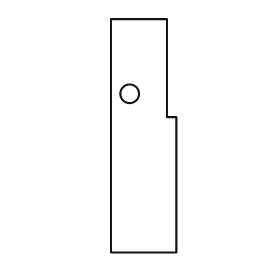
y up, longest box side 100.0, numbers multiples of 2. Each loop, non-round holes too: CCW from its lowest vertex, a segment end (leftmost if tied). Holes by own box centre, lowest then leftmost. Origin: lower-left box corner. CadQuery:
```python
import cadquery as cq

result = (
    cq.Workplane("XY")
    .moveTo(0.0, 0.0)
    .lineTo(28.0, 0.0)
    .lineTo(28.0, 58.0)
    .lineTo(24.0, 58.0)
    .lineTo(24.0, 100.0)
    .lineTo(0.0, 100.0)
    .close()
    .moveTo(8.0, 68.0)
    .circle(4.0)
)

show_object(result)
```